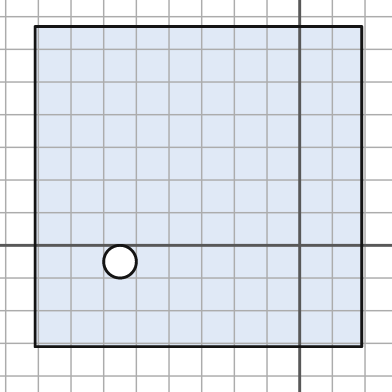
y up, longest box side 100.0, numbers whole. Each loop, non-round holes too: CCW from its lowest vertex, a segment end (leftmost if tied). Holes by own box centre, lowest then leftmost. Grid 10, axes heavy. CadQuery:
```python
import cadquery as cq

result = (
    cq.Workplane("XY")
    .moveTo(-81.0, -31.0)
    .lineTo(19.0, -31.0)
    .lineTo(19.0, 67.0)
    .lineTo(-81.0, 67.0)
    .close()
    .moveTo(-55.0, -5.0)
    .circle(5.0)
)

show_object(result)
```